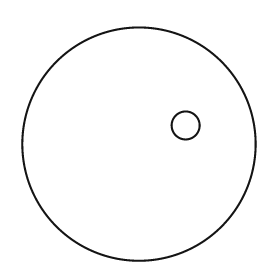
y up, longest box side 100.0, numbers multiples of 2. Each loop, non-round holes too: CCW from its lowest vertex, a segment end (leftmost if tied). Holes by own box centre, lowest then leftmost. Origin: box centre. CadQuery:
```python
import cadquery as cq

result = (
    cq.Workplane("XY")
    .moveTo(0.0, 0.0)
    .circle(50.0)
    .moveTo(20.0, 8.0)
    .circle(6.0)
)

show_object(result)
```